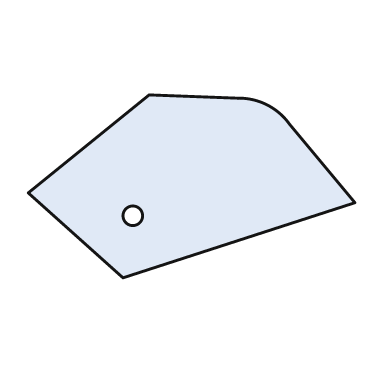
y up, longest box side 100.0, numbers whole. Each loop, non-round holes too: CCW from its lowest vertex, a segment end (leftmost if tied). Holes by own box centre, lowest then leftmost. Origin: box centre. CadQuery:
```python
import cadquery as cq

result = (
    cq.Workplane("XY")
    .moveTo(-21.0, -28.0)
    .lineTo(50.0, -5.0)
    .lineTo(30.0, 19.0)
    .threePointArc((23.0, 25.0), (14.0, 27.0))
    .lineTo(-13.0, 28.0)
    .lineTo(-50.0, -2.0)
    .close()
    .moveTo(-18.0, -9.0)
    .circle(3.0)
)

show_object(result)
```